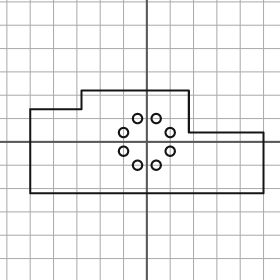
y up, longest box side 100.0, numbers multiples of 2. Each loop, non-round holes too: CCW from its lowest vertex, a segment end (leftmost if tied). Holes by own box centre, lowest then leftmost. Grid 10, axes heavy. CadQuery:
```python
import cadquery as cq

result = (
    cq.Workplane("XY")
    .moveTo(-50.0, -22.0)
    .lineTo(50.0, -22.0)
    .lineTo(50.0, 4.0)
    .lineTo(18.0, 4.0)
    .lineTo(18.0, 22.0)
    .lineTo(-28.0, 22.0)
    .lineTo(-28.0, 14.0)
    .lineTo(-50.0, 14.0)
    .close()
    .moveTo(-4.0, -10.0)
    .circle(2.0)
    .moveTo(4.0, -10.0)
    .circle(2.0)
    .moveTo(-10.0, -4.0)
    .circle(2.0)
    .moveTo(10.0, -4.0)
    .circle(2.0)
    .moveTo(-10.0, 4.0)
    .circle(2.0)
    .moveTo(10.0, 4.0)
    .circle(2.0)
    .moveTo(-4.0, 10.0)
    .circle(2.0)
    .moveTo(4.0, 10.0)
    .circle(2.0)
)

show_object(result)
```